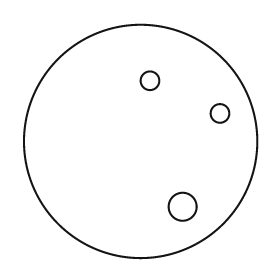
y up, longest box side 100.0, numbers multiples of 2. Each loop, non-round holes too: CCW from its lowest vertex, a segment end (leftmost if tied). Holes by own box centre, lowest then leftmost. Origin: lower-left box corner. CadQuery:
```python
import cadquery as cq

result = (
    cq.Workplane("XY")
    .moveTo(50.0, 50.0)
    .circle(50.0)
    .moveTo(68.0, 22.0)
    .circle(6.0)
    .moveTo(84.0, 62.0)
    .circle(4.0)
    .moveTo(54.0, 76.0)
    .circle(4.0)
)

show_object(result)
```